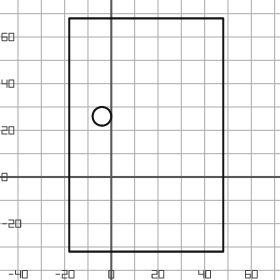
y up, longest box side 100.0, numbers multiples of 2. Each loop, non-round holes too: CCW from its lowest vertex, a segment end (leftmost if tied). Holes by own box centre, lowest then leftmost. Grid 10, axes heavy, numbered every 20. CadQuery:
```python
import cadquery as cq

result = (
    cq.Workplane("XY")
    .moveTo(-18.0, -32.0)
    .lineTo(48.0, -32.0)
    .lineTo(48.0, 68.0)
    .lineTo(-18.0, 68.0)
    .close()
    .moveTo(-4.0, 26.0)
    .circle(4.0)
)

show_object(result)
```